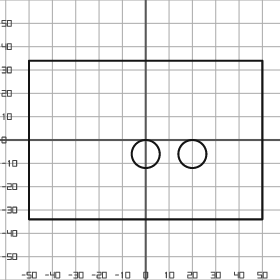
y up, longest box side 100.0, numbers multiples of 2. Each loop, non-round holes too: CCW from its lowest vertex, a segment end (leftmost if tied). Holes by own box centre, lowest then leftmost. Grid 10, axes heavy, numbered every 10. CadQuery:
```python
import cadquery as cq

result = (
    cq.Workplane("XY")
    .moveTo(-50.0, -34.0)
    .lineTo(50.0, -34.0)
    .lineTo(50.0, 34.0)
    .lineTo(-50.0, 34.0)
    .close()
    .moveTo(0.0, -6.0)
    .circle(6.0)
    .moveTo(20.0, -6.0)
    .circle(6.0)
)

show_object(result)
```